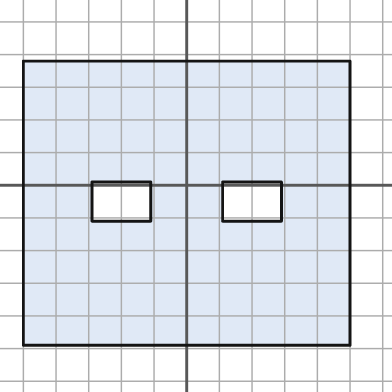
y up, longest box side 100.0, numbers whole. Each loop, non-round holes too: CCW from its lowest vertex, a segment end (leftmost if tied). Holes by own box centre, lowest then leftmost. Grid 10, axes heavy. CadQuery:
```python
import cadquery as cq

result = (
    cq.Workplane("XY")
    .moveTo(-50.0, -49.0)
    .lineTo(50.0, -49.0)
    .lineTo(50.0, 38.0)
    .lineTo(-50.0, 38.0)
    .close()
    .moveTo(-29.0, -11.0)
    .lineTo(-11.0, -11.0)
    .lineTo(-11.0, 1.0)
    .lineTo(-29.0, 1.0)
    .close()
    .moveTo(11.0, -11.0)
    .lineTo(29.0, -11.0)
    .lineTo(29.0, 1.0)
    .lineTo(11.0, 1.0)
    .close()
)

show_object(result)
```